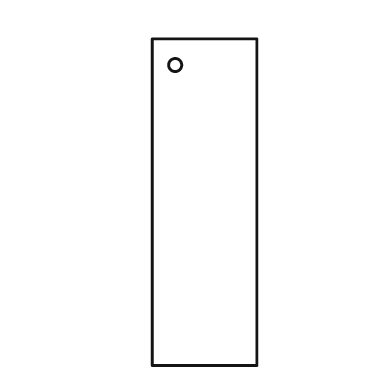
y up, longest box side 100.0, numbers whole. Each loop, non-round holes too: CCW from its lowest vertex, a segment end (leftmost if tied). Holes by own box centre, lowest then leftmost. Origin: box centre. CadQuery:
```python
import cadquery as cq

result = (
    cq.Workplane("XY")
    .moveTo(-16.0, -50.0)
    .lineTo(16.0, -50.0)
    .lineTo(16.0, 50.0)
    .lineTo(-16.0, 50.0)
    .close()
    .moveTo(-9.0, 42.0)
    .circle(2.0)
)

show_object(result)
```